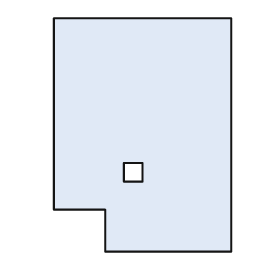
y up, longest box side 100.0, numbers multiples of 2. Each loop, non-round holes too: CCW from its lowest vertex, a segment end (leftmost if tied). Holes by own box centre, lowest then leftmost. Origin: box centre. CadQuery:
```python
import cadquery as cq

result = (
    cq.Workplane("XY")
    .moveTo(-16.0, -50.0)
    .lineTo(38.0, -50.0)
    .lineTo(38.0, 50.0)
    .lineTo(-38.0, 50.0)
    .lineTo(-38.0, -32.0)
    .lineTo(-16.0, -32.0)
    .close()
    .moveTo(-8.0, -20.0)
    .lineTo(0.0, -20.0)
    .lineTo(0.0, -12.0)
    .lineTo(-8.0, -12.0)
    .close()
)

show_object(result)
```